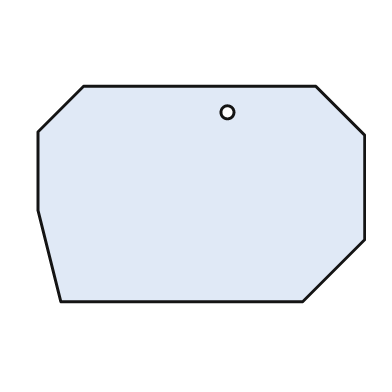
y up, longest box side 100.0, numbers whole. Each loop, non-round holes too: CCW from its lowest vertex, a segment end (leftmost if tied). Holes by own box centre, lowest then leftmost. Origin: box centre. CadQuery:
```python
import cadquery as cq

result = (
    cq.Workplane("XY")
    .moveTo(-43.0, -33.0)
    .lineTo(31.0, -33.0)
    .lineTo(50.0, -14.0)
    .lineTo(50.0, 18.0)
    .lineTo(35.0, 33.0)
    .lineTo(-36.0, 33.0)
    .lineTo(-50.0, 19.0)
    .lineTo(-50.0, -5.0)
    .close()
    .moveTo(8.0, 25.0)
    .circle(2.0)
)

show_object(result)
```